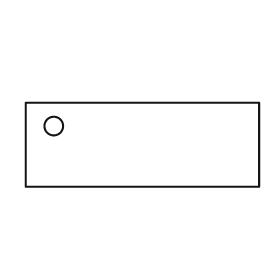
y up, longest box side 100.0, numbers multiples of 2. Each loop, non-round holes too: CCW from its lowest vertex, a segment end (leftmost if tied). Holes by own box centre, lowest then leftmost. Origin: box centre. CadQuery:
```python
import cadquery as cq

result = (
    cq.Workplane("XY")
    .moveTo(-50.0, -18.0)
    .lineTo(50.0, -18.0)
    .lineTo(50.0, 18.0)
    .lineTo(-50.0, 18.0)
    .close()
    .moveTo(-38.0, 8.0)
    .circle(4.0)
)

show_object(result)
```